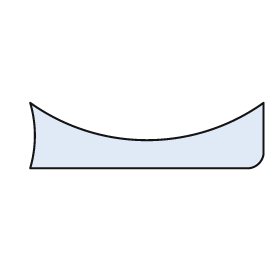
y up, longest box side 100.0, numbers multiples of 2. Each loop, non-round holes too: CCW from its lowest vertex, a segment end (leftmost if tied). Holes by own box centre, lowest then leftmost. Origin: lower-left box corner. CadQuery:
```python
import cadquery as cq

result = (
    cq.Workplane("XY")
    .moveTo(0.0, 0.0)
    .lineTo(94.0, 0.0)
    .threePointArc((98.0, 2.0), (100.0, 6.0))
    .lineTo(100.0, 28.0)
    .threePointArc((50.0, 12.0), (0.0, 28.0))
    .threePointArc((2.0, 14.0), (0.0, 0.0))
    .close()
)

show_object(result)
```